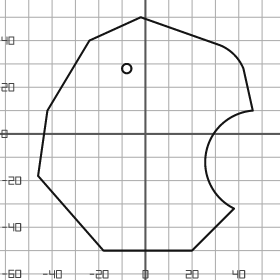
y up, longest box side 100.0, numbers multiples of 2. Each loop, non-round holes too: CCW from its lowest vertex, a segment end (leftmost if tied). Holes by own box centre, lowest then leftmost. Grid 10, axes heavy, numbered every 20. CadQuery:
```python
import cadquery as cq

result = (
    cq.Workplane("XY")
    .moveTo(-18.0, -50.0)
    .lineTo(20.0, -50.0)
    .lineTo(38.0, -32.0)
    .threePointArc((26.0, -8.0), (46.0, 10.0))
    .lineTo(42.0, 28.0)
    .threePointArc((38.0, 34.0), (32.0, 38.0))
    .lineTo(-2.0, 50.0)
    .lineTo(-24.0, 40.0)
    .lineTo(-42.0, 10.0)
    .lineTo(-46.0, -18.0)
    .close()
    .moveTo(-8.0, 28.0)
    .circle(2.0)
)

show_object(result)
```